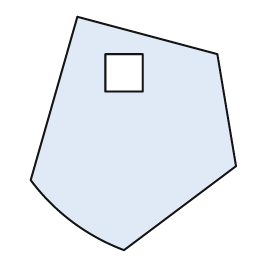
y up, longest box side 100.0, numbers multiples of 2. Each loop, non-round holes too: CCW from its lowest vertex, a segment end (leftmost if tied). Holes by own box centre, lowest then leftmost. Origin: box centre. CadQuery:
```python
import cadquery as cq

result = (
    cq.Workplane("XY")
    .moveTo(-4.0, -50.0)
    .lineTo(44.0, -14.0)
    .lineTo(36.0, 34.0)
    .lineTo(-24.0, 50.0)
    .lineTo(-44.0, -20.0)
    .threePointArc((-26.0, -38.0), (-4.0, -50.0))
    .close()
    .moveTo(-12.0, 18.0)
    .lineTo(4.0, 18.0)
    .lineTo(4.0, 34.0)
    .lineTo(-12.0, 34.0)
    .close()
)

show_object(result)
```